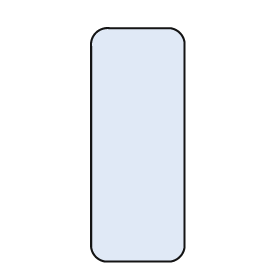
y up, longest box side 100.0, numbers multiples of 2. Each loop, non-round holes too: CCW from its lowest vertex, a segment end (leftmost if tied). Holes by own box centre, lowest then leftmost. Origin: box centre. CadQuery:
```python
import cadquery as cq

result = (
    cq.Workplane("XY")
    .moveTo(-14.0, -50.0)
    .lineTo(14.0, -50.0)
    .threePointArc((18.0, -48.0), (20.0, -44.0))
    .lineTo(20.0, 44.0)
    .threePointArc((18.0, 48.0), (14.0, 50.0))
    .lineTo(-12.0, 50.0)
    .threePointArc((-18.0, 48.0), (-20.0, 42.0))
    .lineTo(-20.0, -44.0)
    .threePointArc((-18.0, -48.0), (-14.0, -50.0))
    .close()
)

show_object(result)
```